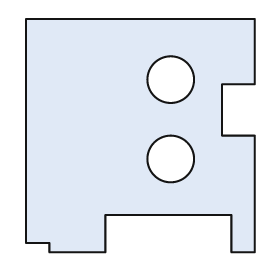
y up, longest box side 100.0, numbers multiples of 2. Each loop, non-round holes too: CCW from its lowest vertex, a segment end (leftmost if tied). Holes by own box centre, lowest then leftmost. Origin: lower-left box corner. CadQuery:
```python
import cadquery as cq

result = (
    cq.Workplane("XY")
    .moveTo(10.0, 0.0)
    .lineTo(34.0, 0.0)
    .lineTo(34.0, 16.0)
    .lineTo(88.0, 16.0)
    .lineTo(88.0, 0.0)
    .lineTo(98.0, 0.0)
    .lineTo(98.0, 50.0)
    .lineTo(84.0, 50.0)
    .lineTo(84.0, 72.0)
    .lineTo(98.0, 72.0)
    .lineTo(98.0, 100.0)
    .lineTo(0.0, 100.0)
    .lineTo(0.0, 4.0)
    .lineTo(10.0, 4.0)
    .close()
    .moveTo(62.0, 40.0)
    .circle(10.0)
    .moveTo(62.0, 74.0)
    .circle(10.0)
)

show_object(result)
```